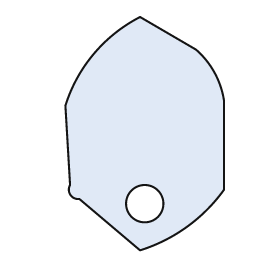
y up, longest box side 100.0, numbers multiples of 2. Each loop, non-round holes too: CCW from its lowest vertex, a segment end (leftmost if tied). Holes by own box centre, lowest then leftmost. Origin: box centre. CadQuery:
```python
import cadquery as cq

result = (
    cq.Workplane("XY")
    .moveTo(-2.0, -50.0)
    .threePointArc((18.0, -40.0), (34.0, -24.0))
    .lineTo(34.0, 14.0)
    .threePointArc((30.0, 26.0), (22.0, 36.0))
    .lineTo(-2.0, 50.0)
    .threePointArc((-22.0, 34.0), (-34.0, 12.0))
    .lineTo(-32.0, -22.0)
    .threePointArc((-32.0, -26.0), (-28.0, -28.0))
    .close()
    .moveTo(0.0, -30.0)
    .circle(8.0)
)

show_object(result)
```